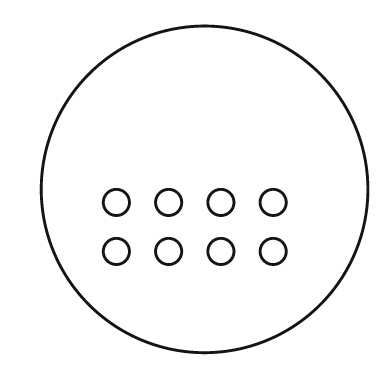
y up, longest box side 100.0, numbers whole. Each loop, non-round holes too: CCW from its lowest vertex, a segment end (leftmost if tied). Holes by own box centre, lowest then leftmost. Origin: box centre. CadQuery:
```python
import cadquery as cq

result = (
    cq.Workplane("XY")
    .moveTo(0.0, 0.0)
    .circle(50.0)
    .moveTo(-27.0, -19.0)
    .circle(4.0)
    .moveTo(-11.0, -19.0)
    .circle(4.0)
    .moveTo(5.0, -19.0)
    .circle(4.0)
    .moveTo(21.0, -19.0)
    .circle(4.0)
    .moveTo(-27.0, -4.0)
    .circle(4.0)
    .moveTo(-11.0, -4.0)
    .circle(4.0)
    .moveTo(5.0, -4.0)
    .circle(4.0)
    .moveTo(21.0, -4.0)
    .circle(4.0)
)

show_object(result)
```